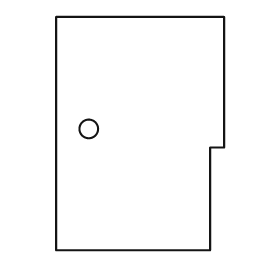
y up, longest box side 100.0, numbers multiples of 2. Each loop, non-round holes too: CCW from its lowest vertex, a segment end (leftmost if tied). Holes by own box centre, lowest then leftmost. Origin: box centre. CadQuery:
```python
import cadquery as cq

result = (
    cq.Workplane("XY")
    .moveTo(-36.0, -50.0)
    .lineTo(30.0, -50.0)
    .lineTo(30.0, -6.0)
    .lineTo(36.0, -6.0)
    .lineTo(36.0, 50.0)
    .lineTo(-36.0, 50.0)
    .close()
    .moveTo(-22.0, 2.0)
    .circle(4.0)
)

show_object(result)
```